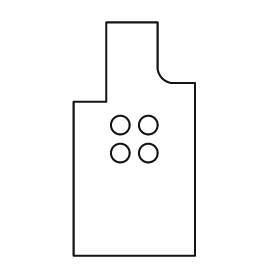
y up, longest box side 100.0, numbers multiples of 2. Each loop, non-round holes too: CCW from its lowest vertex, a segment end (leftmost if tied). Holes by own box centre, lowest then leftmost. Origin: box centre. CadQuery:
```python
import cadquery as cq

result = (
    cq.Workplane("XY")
    .moveTo(-26.0, -50.0)
    .lineTo(26.0, -50.0)
    .lineTo(26.0, 24.0)
    .lineTo(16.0, 24.0)
    .threePointArc((12.0, 26.0), (10.0, 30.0))
    .lineTo(10.0, 50.0)
    .lineTo(-12.0, 50.0)
    .lineTo(-12.0, 16.0)
    .lineTo(-26.0, 16.0)
    .close()
    .moveTo(-6.0, -6.0)
    .circle(4.0)
    .moveTo(6.0, -6.0)
    .circle(4.0)
    .moveTo(-6.0, 6.0)
    .circle(4.0)
    .moveTo(6.0, 6.0)
    .circle(4.0)
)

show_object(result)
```